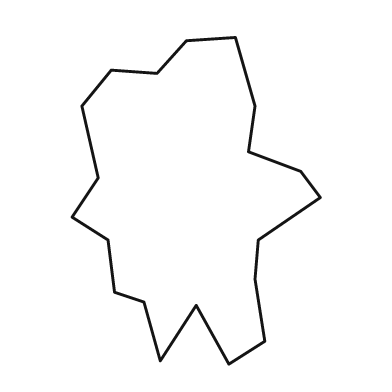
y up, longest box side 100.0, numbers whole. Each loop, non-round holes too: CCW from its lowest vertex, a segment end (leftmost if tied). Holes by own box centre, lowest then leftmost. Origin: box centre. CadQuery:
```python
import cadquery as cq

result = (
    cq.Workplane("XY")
    .moveTo(10.0, -50.0)
    .lineTo(21.0, -43.0)
    .lineTo(18.0, -24.0)
    .lineTo(19.0, -12.0)
    .lineTo(38.0, 1.0)
    .lineTo(32.0, 9.0)
    .lineTo(16.0, 15.0)
    .lineTo(18.0, 29.0)
    .lineTo(12.0, 50.0)
    .lineTo(-3.0, 49.0)
    .lineTo(-12.0, 39.0)
    .lineTo(-26.0, 40.0)
    .lineTo(-35.0, 29.0)
    .lineTo(-30.0, 7.0)
    .lineTo(-38.0, -5.0)
    .lineTo(-27.0, -12.0)
    .lineTo(-25.0, -28.0)
    .lineTo(-16.0, -31.0)
    .lineTo(-11.0, -49.0)
    .lineTo(0.0, -32.0)
    .close()
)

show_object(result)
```